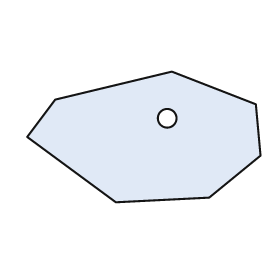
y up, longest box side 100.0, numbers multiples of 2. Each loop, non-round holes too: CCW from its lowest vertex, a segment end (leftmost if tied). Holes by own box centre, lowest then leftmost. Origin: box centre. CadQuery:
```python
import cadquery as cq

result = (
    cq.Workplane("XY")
    .moveTo(-12.0, -28.0)
    .lineTo(28.0, -26.0)
    .lineTo(50.0, -8.0)
    .lineTo(48.0, 14.0)
    .lineTo(12.0, 28.0)
    .lineTo(-38.0, 16.0)
    .lineTo(-50.0, 0.0)
    .close()
    .moveTo(10.0, 8.0)
    .circle(4.0)
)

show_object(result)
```